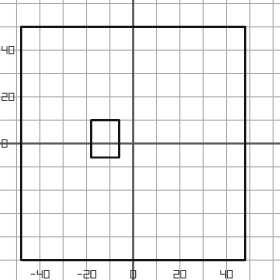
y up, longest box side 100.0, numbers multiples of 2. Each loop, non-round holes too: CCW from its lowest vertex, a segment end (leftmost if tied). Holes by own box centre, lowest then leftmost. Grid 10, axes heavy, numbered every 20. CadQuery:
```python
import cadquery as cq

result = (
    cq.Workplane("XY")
    .moveTo(-48.0, -50.0)
    .lineTo(48.0, -50.0)
    .lineTo(48.0, 50.0)
    .lineTo(-48.0, 50.0)
    .close()
    .moveTo(-18.0, -6.0)
    .lineTo(-6.0, -6.0)
    .lineTo(-6.0, 10.0)
    .lineTo(-18.0, 10.0)
    .close()
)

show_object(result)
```